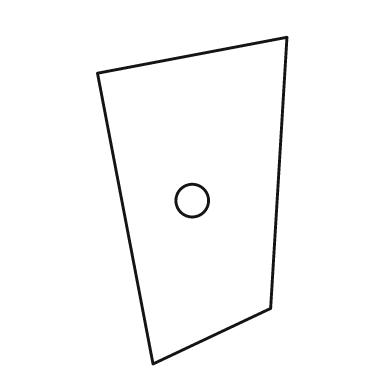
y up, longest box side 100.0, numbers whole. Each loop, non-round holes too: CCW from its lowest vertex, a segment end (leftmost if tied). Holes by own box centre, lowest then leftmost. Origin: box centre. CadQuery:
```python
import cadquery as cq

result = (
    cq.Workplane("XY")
    .moveTo(-12.0, -50.0)
    .lineTo(24.0, -33.0)
    .lineTo(29.0, 50.0)
    .lineTo(-29.0, 39.0)
    .close()
    .moveTo(0.0, 0.0)
    .circle(5.0)
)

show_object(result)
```